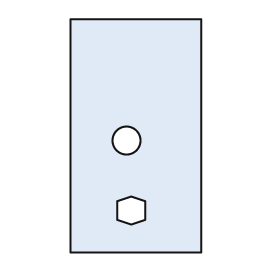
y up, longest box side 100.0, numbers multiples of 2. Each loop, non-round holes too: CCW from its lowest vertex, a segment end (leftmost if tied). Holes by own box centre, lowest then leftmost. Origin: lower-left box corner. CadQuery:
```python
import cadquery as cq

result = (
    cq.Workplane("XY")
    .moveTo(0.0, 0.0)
    .lineTo(56.0, 0.0)
    .lineTo(56.0, 100.0)
    .lineTo(0.0, 100.0)
    .close()
    .moveTo(26.0, 12.0)
    .lineTo(32.0, 14.0)
    .lineTo(32.0, 22.0)
    .lineTo(26.0, 24.0)
    .lineTo(20.0, 22.0)
    .lineTo(20.0, 14.0)
    .close()
    .moveTo(24.0, 48.0)
    .circle(6.0)
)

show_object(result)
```